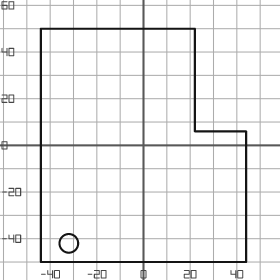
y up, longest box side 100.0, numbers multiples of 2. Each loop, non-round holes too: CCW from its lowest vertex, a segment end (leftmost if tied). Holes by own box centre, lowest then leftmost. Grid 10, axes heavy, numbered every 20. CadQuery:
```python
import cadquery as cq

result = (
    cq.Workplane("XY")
    .moveTo(-44.0, -50.0)
    .lineTo(44.0, -50.0)
    .lineTo(44.0, 6.0)
    .lineTo(22.0, 6.0)
    .lineTo(22.0, 50.0)
    .lineTo(-44.0, 50.0)
    .close()
    .moveTo(-32.0, -42.0)
    .circle(4.0)
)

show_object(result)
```